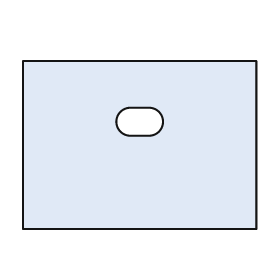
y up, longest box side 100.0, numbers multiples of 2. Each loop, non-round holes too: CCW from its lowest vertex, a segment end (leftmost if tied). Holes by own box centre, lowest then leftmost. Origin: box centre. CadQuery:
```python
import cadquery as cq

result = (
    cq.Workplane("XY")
    .moveTo(-50.0, -36.0)
    .lineTo(50.0, -36.0)
    .lineTo(50.0, 36.0)
    .lineTo(-50.0, 36.0)
    .close()
    .moveTo(-4.0, 4.0)
    .lineTo(4.0, 4.0)
    .threePointArc((10.0, 10.0), (4.0, 16.0))
    .lineTo(-4.0, 16.0)
    .threePointArc((-10.0, 10.0), (-4.0, 4.0))
    .close()
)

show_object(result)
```